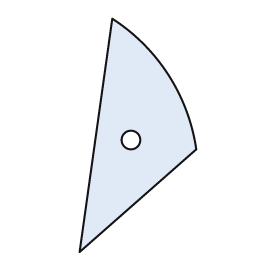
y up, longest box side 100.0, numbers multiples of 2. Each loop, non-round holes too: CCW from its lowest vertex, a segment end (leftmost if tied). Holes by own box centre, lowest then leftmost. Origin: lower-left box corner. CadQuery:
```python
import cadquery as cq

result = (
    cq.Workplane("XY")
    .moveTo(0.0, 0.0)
    .lineTo(50.0, 44.0)
    .threePointArc((38.0, 76.0), (14.0, 100.0))
    .close()
    .moveTo(22.0, 48.0)
    .circle(4.0)
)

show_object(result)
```